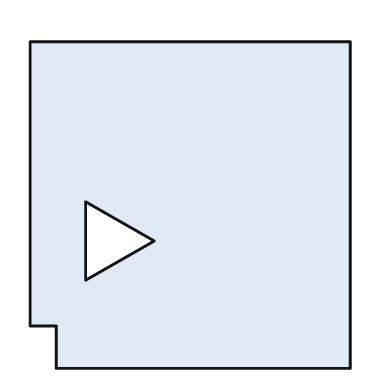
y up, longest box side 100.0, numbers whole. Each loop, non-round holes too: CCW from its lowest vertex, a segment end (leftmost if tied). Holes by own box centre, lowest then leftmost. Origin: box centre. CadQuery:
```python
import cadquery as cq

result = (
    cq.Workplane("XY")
    .moveTo(-41.0, -50.0)
    .lineTo(49.0, -50.0)
    .lineTo(49.0, 50.0)
    .lineTo(-49.0, 50.0)
    .lineTo(-49.0, -37.0)
    .lineTo(-41.0, -37.0)
    .close()
    .moveTo(-32.0, -23.0)
    .lineTo(-11.0, -11.0)
    .lineTo(-32.0, 1.0)
    .close()
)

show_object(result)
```